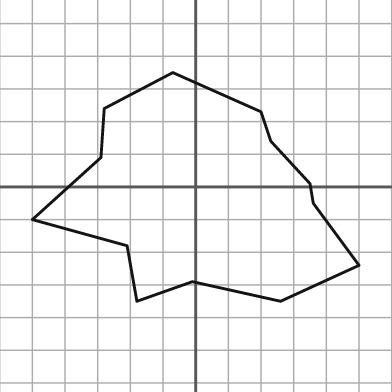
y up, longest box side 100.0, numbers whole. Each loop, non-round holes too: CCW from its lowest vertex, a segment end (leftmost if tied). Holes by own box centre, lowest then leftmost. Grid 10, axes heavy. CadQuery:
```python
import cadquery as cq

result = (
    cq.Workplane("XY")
    .moveTo(-18.0, -35.0)
    .lineTo(-1.0, -29.0)
    .lineTo(26.0, -35.0)
    .lineTo(50.0, -24.0)
    .lineTo(36.0, -5.0)
    .lineTo(35.0, 1.0)
    .lineTo(23.0, 14.0)
    .lineTo(20.0, 23.0)
    .lineTo(-7.0, 35.0)
    .lineTo(-28.0, 24.0)
    .lineTo(-29.0, 9.0)
    .lineTo(-50.0, -10.0)
    .lineTo(-21.0, -18.0)
    .close()
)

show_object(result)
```